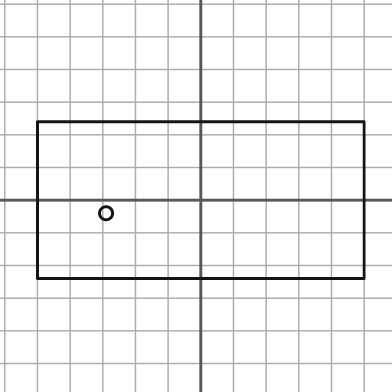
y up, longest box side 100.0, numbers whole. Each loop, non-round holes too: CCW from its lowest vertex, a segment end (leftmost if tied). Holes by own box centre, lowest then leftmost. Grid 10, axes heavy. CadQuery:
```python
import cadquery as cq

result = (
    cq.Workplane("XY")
    .moveTo(-50.0, -24.0)
    .lineTo(50.0, -24.0)
    .lineTo(50.0, 24.0)
    .lineTo(-50.0, 24.0)
    .close()
    .moveTo(-29.0, -4.0)
    .circle(2.0)
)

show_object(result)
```